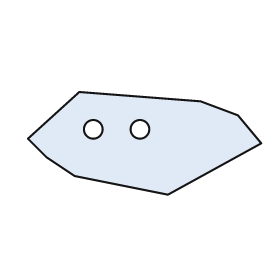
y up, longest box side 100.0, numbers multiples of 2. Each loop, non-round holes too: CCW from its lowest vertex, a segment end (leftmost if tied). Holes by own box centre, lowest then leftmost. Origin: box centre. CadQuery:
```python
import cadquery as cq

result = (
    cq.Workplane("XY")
    .moveTo(10.0, -22.0)
    .lineTo(50.0, 0.0)
    .lineTo(40.0, 12.0)
    .lineTo(24.0, 18.0)
    .lineTo(-28.0, 22.0)
    .lineTo(-50.0, 2.0)
    .lineTo(-42.0, -6.0)
    .lineTo(-30.0, -14.0)
    .close()
    .moveTo(-22.0, 6.0)
    .circle(4.0)
    .moveTo(-2.0, 6.0)
    .circle(4.0)
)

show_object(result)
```